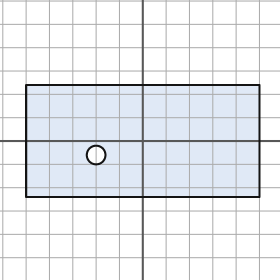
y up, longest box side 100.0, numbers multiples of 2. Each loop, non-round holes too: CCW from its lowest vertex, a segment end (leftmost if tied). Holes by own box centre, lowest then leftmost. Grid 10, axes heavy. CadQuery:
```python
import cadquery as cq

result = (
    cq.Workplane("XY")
    .moveTo(-50.0, -24.0)
    .lineTo(50.0, -24.0)
    .lineTo(50.0, 24.0)
    .lineTo(-50.0, 24.0)
    .close()
    .moveTo(-20.0, -6.0)
    .circle(4.0)
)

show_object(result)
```